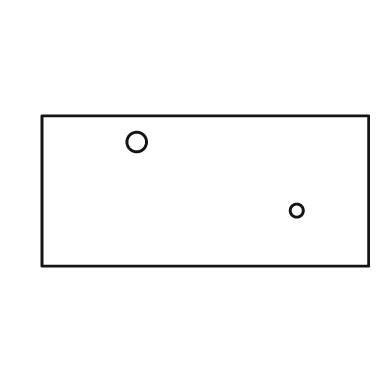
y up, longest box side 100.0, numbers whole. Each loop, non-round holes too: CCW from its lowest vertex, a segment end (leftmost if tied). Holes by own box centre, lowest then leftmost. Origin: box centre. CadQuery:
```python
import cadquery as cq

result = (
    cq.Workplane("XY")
    .moveTo(-50.0, -23.0)
    .lineTo(50.0, -23.0)
    .lineTo(50.0, 23.0)
    .lineTo(-50.0, 23.0)
    .close()
    .moveTo(28.0, -6.0)
    .circle(2.0)
    .moveTo(-21.0, 15.0)
    .circle(3.0)
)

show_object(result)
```